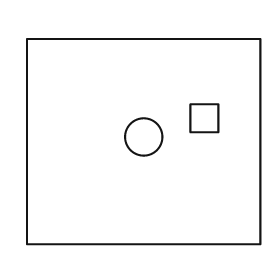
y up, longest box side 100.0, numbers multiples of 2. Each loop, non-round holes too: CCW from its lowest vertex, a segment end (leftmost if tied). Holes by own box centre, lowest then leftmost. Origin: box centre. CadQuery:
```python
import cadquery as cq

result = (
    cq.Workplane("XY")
    .moveTo(-50.0, -44.0)
    .lineTo(50.0, -44.0)
    .lineTo(50.0, 44.0)
    .lineTo(-50.0, 44.0)
    .close()
    .moveTo(0.0, 2.0)
    .circle(8.0)
    .moveTo(20.0, 4.0)
    .lineTo(32.0, 4.0)
    .lineTo(32.0, 16.0)
    .lineTo(20.0, 16.0)
    .close()
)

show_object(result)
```